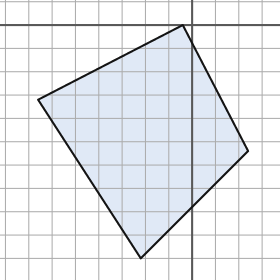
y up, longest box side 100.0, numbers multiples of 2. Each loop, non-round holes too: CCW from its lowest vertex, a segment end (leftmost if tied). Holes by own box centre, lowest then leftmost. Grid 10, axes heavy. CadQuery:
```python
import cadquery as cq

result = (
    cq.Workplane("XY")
    .moveTo(-22.0, -100.0)
    .lineTo(24.0, -54.0)
    .lineTo(-4.0, 0.0)
    .lineTo(-66.0, -32.0)
    .close()
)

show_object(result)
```